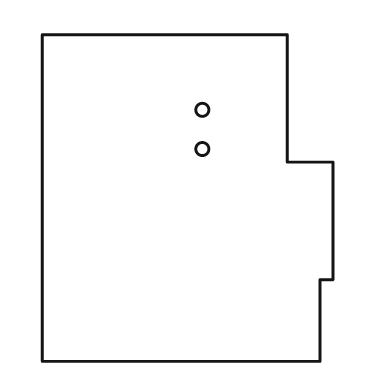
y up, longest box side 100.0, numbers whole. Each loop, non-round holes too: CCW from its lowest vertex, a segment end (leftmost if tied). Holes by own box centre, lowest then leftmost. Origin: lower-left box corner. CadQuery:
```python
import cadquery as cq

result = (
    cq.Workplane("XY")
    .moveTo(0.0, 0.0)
    .lineTo(85.0, 0.0)
    .lineTo(85.0, 25.0)
    .lineTo(89.0, 25.0)
    .lineTo(89.0, 61.0)
    .lineTo(75.0, 61.0)
    .lineTo(75.0, 100.0)
    .lineTo(0.0, 100.0)
    .close()
    .moveTo(49.0, 65.0)
    .circle(2.0)
    .moveTo(49.0, 77.0)
    .circle(2.0)
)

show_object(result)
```